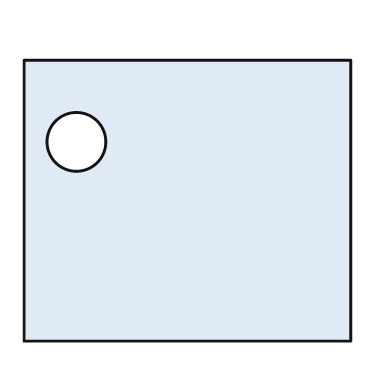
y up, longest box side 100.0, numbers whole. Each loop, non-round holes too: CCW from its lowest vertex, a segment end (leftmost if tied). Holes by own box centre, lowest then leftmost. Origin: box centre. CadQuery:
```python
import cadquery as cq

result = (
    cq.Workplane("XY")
    .moveTo(-50.0, -43.0)
    .lineTo(50.0, -43.0)
    .lineTo(50.0, 43.0)
    .lineTo(-50.0, 43.0)
    .close()
    .moveTo(-34.0, 18.0)
    .circle(9.0)
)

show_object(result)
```